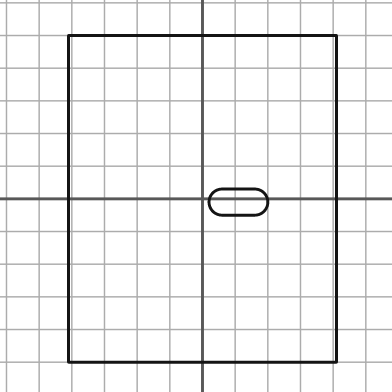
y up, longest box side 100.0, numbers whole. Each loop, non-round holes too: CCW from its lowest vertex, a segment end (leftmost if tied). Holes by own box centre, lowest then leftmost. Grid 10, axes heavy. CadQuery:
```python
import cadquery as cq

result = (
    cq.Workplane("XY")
    .moveTo(-41.0, -50.0)
    .lineTo(41.0, -50.0)
    .lineTo(41.0, 50.0)
    .lineTo(-41.0, 50.0)
    .close()
    .moveTo(6.0, -5.0)
    .lineTo(16.0, -5.0)
    .threePointArc((20.0, -1.0), (16.0, 3.0))
    .lineTo(6.0, 3.0)
    .threePointArc((2.0, -1.0), (6.0, -5.0))
    .close()
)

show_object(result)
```